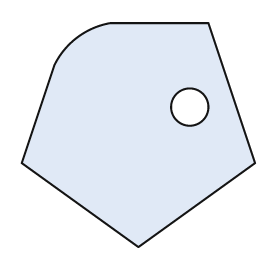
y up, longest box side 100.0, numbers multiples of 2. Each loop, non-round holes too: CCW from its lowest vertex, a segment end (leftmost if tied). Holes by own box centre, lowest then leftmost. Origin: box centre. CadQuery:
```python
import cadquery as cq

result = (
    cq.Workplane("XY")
    .moveTo(0.0, -48.0)
    .lineTo(50.0, -12.0)
    .lineTo(30.0, 48.0)
    .lineTo(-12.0, 48.0)
    .threePointArc((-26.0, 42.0), (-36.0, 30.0))
    .lineTo(-50.0, -12.0)
    .close()
    .moveTo(22.0, 12.0)
    .circle(8.0)
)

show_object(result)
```